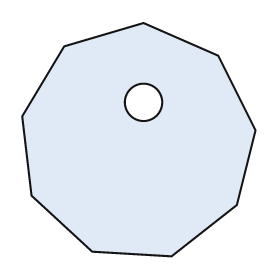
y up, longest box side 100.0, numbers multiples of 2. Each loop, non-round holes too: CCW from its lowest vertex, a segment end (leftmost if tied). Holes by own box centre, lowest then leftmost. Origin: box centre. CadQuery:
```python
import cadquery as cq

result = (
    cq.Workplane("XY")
    .moveTo(14.0, -50.0)
    .lineTo(42.0, -28.0)
    .lineTo(50.0, 4.0)
    .lineTo(34.0, 36.0)
    .lineTo(2.0, 50.0)
    .lineTo(-32.0, 40.0)
    .lineTo(-50.0, 10.0)
    .lineTo(-46.0, -24.0)
    .lineTo(-20.0, -48.0)
    .close()
    .moveTo(2.0, 16.0)
    .circle(8.0)
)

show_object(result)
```